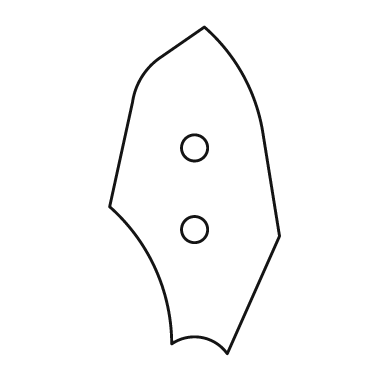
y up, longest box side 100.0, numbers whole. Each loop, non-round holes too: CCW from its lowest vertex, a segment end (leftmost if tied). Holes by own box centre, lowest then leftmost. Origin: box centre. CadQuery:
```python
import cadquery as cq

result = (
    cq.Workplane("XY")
    .moveTo(10.0, -50.0)
    .lineTo(26.0, -14.0)
    .lineTo(21.0, 17.0)
    .threePointArc((15.0, 35.0), (3.0, 50.0))
    .lineTo(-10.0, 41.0)
    .threePointArc((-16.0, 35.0), (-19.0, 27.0))
    .lineTo(-26.0, -5.0)
    .threePointArc((-12.0, -24.0), (-7.0, -47.0))
    .threePointArc((2.0, -45.0), (10.0, -50.0))
    .close()
    .moveTo(0.0, -12.0)
    .circle(4.0)
    .moveTo(0.0, 13.0)
    .circle(4.0)
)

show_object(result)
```